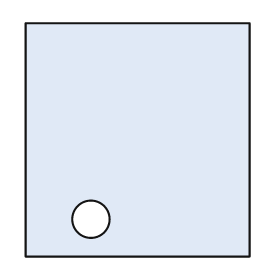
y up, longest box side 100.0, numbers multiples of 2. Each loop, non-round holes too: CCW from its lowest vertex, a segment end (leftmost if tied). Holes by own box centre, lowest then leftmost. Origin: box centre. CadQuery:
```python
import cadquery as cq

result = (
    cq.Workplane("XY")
    .moveTo(-48.0, -50.0)
    .lineTo(48.0, -50.0)
    .lineTo(48.0, 50.0)
    .lineTo(-48.0, 50.0)
    .close()
    .moveTo(-20.0, -34.0)
    .circle(8.0)
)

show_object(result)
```